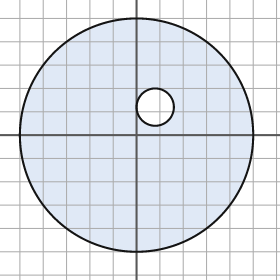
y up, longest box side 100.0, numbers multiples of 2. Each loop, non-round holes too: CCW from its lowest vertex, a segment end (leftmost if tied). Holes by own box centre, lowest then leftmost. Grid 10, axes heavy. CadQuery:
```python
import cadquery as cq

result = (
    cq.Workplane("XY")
    .moveTo(0.0, 0.0)
    .circle(50.0)
    .moveTo(8.0, 12.0)
    .circle(8.0)
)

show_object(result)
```